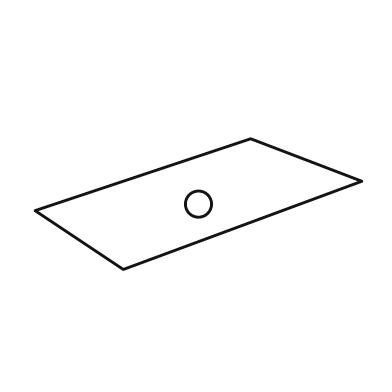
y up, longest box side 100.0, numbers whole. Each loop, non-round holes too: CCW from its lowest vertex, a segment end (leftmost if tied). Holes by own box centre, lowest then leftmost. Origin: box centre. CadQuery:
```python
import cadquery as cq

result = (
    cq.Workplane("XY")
    .moveTo(-23.0, -20.0)
    .lineTo(50.0, 7.0)
    .lineTo(16.0, 20.0)
    .lineTo(-50.0, -2.0)
    .close()
    .moveTo(0.0, 0.0)
    .circle(4.0)
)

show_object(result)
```